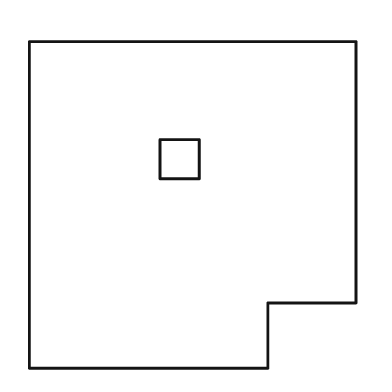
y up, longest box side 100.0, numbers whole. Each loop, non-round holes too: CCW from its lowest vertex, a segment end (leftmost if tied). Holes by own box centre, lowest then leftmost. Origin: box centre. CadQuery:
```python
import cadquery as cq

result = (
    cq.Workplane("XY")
    .moveTo(-50.0, -50.0)
    .lineTo(23.0, -50.0)
    .lineTo(23.0, -30.0)
    .lineTo(50.0, -30.0)
    .lineTo(50.0, 50.0)
    .lineTo(-50.0, 50.0)
    .close()
    .moveTo(-10.0, 8.0)
    .lineTo(2.0, 8.0)
    .lineTo(2.0, 20.0)
    .lineTo(-10.0, 20.0)
    .close()
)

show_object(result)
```